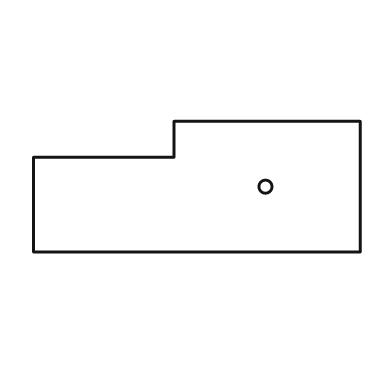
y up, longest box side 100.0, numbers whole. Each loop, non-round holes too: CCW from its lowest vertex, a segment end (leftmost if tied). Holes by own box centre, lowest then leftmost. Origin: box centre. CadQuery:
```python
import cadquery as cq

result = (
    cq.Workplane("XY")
    .moveTo(-50.0, -20.0)
    .lineTo(50.0, -20.0)
    .lineTo(50.0, 20.0)
    .lineTo(-7.0, 20.0)
    .lineTo(-7.0, 9.0)
    .lineTo(-50.0, 9.0)
    .close()
    .moveTo(21.0, 0.0)
    .circle(2.0)
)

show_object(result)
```